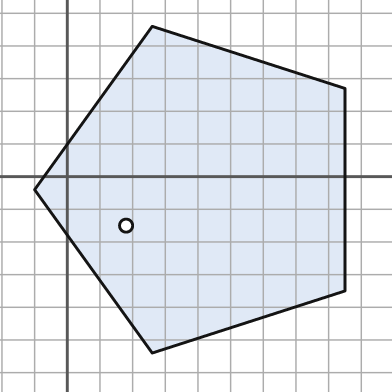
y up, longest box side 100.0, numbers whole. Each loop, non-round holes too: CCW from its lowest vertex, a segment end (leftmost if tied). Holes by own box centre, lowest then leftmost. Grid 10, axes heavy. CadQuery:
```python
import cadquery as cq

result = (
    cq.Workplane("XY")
    .moveTo(26.0, -54.0)
    .lineTo(85.0, -35.0)
    .lineTo(85.0, 27.0)
    .lineTo(26.0, 46.0)
    .lineTo(-10.0, -4.0)
    .close()
    .moveTo(18.0, -15.0)
    .circle(2.0)
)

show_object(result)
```